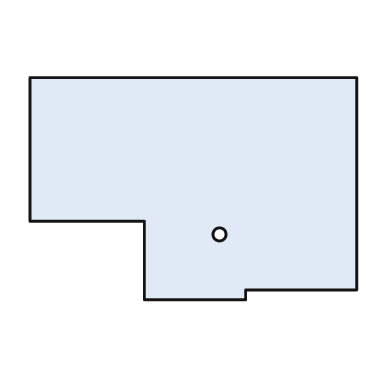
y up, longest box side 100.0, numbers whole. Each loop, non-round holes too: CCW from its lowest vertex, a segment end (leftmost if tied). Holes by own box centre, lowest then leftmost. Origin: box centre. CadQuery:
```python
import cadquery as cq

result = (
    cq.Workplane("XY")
    .moveTo(-15.0, -34.0)
    .lineTo(16.0, -34.0)
    .lineTo(16.0, -31.0)
    .lineTo(50.0, -31.0)
    .lineTo(50.0, 34.0)
    .lineTo(-50.0, 34.0)
    .lineTo(-50.0, -10.0)
    .lineTo(-15.0, -10.0)
    .close()
    .moveTo(8.0, -14.0)
    .circle(2.0)
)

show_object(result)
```